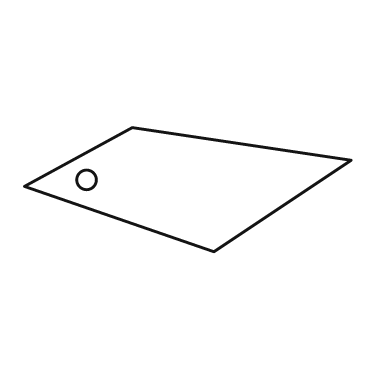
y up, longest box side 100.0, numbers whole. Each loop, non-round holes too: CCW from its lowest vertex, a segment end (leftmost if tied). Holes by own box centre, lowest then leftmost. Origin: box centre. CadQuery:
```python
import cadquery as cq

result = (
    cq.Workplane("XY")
    .moveTo(8.0, -19.0)
    .lineTo(50.0, 9.0)
    .lineTo(-17.0, 19.0)
    .lineTo(-50.0, 1.0)
    .close()
    .moveTo(-31.0, 3.0)
    .circle(3.0)
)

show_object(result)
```